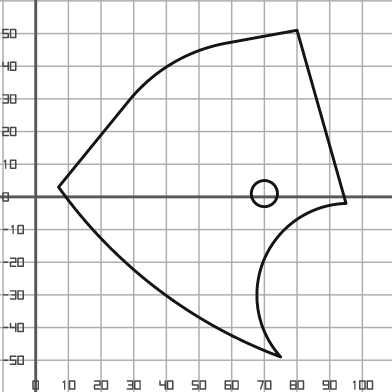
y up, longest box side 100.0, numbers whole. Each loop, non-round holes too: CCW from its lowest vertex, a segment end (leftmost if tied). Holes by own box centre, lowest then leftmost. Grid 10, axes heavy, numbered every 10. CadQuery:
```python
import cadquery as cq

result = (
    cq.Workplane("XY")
    .moveTo(75.0, -49.0)
    .threePointArc((70.0, -19.0), (95.0, -2.0))
    .lineTo(80.0, 51.0)
    .lineTo(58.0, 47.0)
    .threePointArc((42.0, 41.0), (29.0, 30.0))
    .lineTo(7.0, 3.0)
    .threePointArc((37.0, -28.0), (75.0, -49.0))
    .close()
    .moveTo(70.0, 1.0)
    .circle(4.0)
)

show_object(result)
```